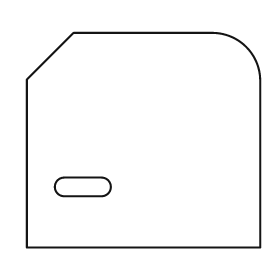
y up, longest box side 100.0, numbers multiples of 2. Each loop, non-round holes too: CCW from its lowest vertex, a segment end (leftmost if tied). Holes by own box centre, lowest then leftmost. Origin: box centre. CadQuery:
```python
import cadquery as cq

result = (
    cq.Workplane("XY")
    .moveTo(-50.0, -46.0)
    .lineTo(50.0, -46.0)
    .lineTo(50.0, 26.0)
    .threePointArc((44.0, 40.0), (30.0, 46.0))
    .lineTo(-30.0, 46.0)
    .lineTo(-50.0, 26.0)
    .close()
    .moveTo(-34.0, -24.0)
    .lineTo(-18.0, -24.0)
    .threePointArc((-14.0, -20.0), (-18.0, -16.0))
    .lineTo(-34.0, -16.0)
    .threePointArc((-38.0, -20.0), (-34.0, -24.0))
    .close()
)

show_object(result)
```